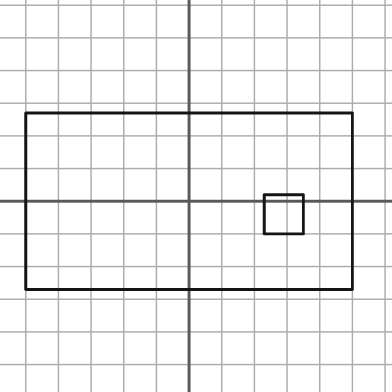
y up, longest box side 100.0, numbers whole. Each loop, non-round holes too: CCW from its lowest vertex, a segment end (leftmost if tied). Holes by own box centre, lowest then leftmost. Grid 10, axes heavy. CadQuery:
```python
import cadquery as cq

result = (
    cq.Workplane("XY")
    .moveTo(-50.0, -27.0)
    .lineTo(50.0, -27.0)
    .lineTo(50.0, 27.0)
    .lineTo(-50.0, 27.0)
    .close()
    .moveTo(23.0, -10.0)
    .lineTo(35.0, -10.0)
    .lineTo(35.0, 2.0)
    .lineTo(23.0, 2.0)
    .close()
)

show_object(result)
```